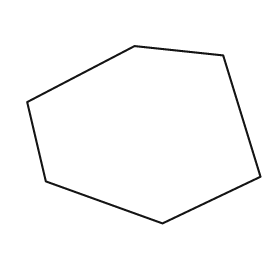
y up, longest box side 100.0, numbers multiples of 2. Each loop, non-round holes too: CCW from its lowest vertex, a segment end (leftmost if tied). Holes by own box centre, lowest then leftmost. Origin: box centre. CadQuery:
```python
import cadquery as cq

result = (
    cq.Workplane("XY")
    .moveTo(8.0, -38.0)
    .lineTo(50.0, -18.0)
    .lineTo(34.0, 34.0)
    .lineTo(-4.0, 38.0)
    .lineTo(-50.0, 14.0)
    .lineTo(-42.0, -20.0)
    .close()
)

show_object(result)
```